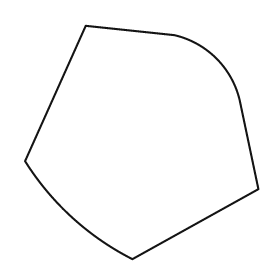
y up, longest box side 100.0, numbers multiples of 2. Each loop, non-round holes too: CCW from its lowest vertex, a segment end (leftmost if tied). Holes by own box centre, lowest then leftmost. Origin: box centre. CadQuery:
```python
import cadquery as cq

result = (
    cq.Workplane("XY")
    .moveTo(-4.0, -50.0)
    .lineTo(50.0, -20.0)
    .lineTo(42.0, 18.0)
    .threePointArc((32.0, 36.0), (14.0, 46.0))
    .lineTo(-24.0, 50.0)
    .lineTo(-50.0, -8.0)
    .threePointArc((-30.0, -32.0), (-4.0, -50.0))
    .close()
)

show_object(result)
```